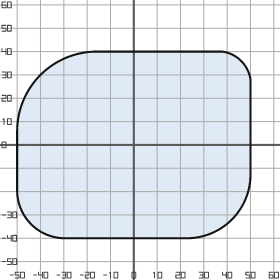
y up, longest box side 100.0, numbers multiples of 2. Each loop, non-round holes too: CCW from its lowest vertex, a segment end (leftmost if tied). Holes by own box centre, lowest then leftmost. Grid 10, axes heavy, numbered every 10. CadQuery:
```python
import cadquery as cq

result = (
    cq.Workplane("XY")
    .moveTo(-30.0, -40.0)
    .lineTo(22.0, -40.0)
    .threePointArc((42.0, -32.0), (50.0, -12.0))
    .lineTo(50.0, 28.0)
    .threePointArc((46.0, 36.0), (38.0, 40.0))
    .lineTo(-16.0, 40.0)
    .threePointArc((-40.0, 30.0), (-50.0, 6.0))
    .lineTo(-50.0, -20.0)
    .threePointArc((-44.0, -34.0), (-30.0, -40.0))
    .close()
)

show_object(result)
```